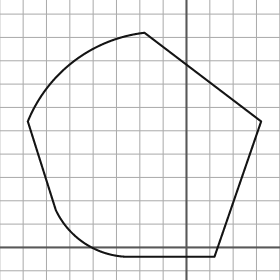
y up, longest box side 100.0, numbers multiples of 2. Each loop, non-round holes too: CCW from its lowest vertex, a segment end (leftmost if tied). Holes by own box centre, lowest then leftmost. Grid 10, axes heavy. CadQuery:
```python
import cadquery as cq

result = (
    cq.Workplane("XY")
    .moveTo(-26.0, -4.0)
    .lineTo(12.0, -4.0)
    .lineTo(32.0, 54.0)
    .lineTo(-18.0, 92.0)
    .threePointArc((-48.0, 80.0), (-68.0, 54.0))
    .lineTo(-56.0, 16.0)
    .threePointArc((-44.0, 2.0), (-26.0, -4.0))
    .close()
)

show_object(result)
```